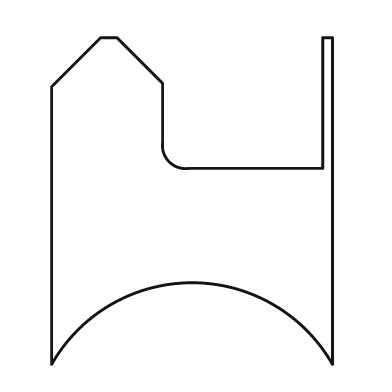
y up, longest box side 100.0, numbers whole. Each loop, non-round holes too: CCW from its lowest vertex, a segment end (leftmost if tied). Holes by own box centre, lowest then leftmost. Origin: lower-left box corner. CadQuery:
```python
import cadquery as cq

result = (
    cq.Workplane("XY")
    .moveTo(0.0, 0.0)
    .threePointArc((43.0, 25.0), (86.0, 0.0))
    .lineTo(86.0, 100.0)
    .lineTo(83.0, 100.0)
    .lineTo(83.0, 60.0)
    .lineTo(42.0, 60.0)
    .threePointArc((36.0, 62.0), (34.0, 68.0))
    .lineTo(34.0, 86.0)
    .lineTo(20.0, 100.0)
    .lineTo(15.0, 100.0)
    .lineTo(0.0, 85.0)
    .close()
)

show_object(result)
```